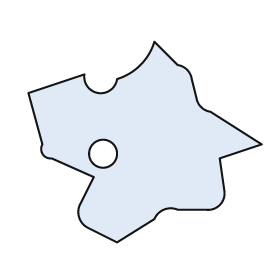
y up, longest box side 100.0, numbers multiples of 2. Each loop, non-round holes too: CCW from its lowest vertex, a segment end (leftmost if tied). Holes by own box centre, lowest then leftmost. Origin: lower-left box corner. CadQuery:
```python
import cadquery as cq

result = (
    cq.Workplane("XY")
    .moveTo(38.0, 0.0)
    .lineTo(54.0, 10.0)
    .threePointArc((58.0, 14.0), (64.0, 14.0))
    .lineTo(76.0, 14.0)
    .threePointArc((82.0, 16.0), (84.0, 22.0))
    .lineTo(82.0, 36.0)
    .lineTo(100.0, 42.0)
    .lineTo(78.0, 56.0)
    .threePointArc((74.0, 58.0), (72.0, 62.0))
    .lineTo(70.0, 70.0)
    .threePointArc((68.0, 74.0), (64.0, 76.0))
    .lineTo(54.0, 86.0)
    .threePointArc((48.0, 76.0), (38.0, 70.0))
    .threePointArc((30.0, 64.0), (24.0, 72.0))
    .lineTo(0.0, 64.0)
    .lineTo(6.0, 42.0)
    .threePointArc((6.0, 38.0), (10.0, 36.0))
    .lineTo(28.0, 28.0)
    .lineTo(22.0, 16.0)
    .threePointArc((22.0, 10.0), (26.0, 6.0))
    .close()
    .moveTo(32.0, 38.0)
    .circle(6.0)
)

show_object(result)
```